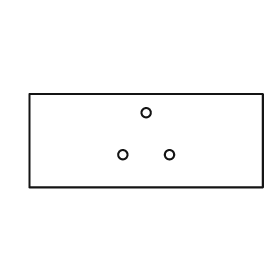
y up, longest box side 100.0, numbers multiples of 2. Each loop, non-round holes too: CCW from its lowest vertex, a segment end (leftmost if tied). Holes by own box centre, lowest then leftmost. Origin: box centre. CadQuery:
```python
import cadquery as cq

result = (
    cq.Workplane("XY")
    .moveTo(-50.0, -20.0)
    .lineTo(50.0, -20.0)
    .lineTo(50.0, 20.0)
    .lineTo(-50.0, 20.0)
    .close()
    .moveTo(-10.0, -6.0)
    .circle(2.0)
    .moveTo(10.0, -6.0)
    .circle(2.0)
    .moveTo(0.0, 12.0)
    .circle(2.0)
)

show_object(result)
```